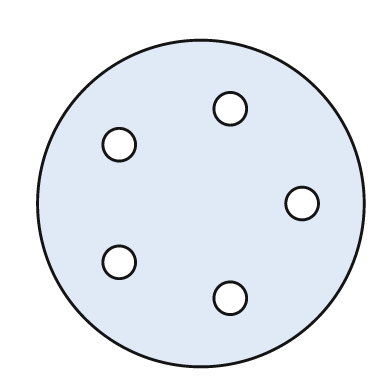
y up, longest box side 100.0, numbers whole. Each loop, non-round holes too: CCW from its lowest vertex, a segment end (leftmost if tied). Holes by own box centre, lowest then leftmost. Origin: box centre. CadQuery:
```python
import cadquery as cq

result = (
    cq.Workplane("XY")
    .moveTo(0.0, 0.0)
    .circle(50.0)
    .moveTo(9.0, -29.0)
    .circle(5.0)
    .moveTo(-25.0, -18.0)
    .circle(5.0)
    .moveTo(31.0, 0.0)
    .circle(5.0)
    .moveTo(-25.0, 18.0)
    .circle(5.0)
    .moveTo(9.0, 29.0)
    .circle(5.0)
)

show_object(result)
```